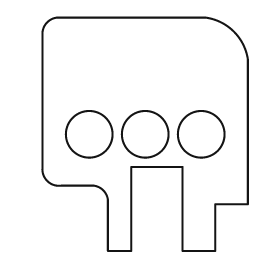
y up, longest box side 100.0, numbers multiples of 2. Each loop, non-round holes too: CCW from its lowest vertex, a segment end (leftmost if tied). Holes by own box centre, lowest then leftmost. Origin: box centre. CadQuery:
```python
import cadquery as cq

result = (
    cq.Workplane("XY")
    .moveTo(-16.0, -50.0)
    .lineTo(-6.0, -50.0)
    .lineTo(-6.0, -14.0)
    .lineTo(16.0, -14.0)
    .lineTo(16.0, -50.0)
    .lineTo(30.0, -50.0)
    .lineTo(30.0, -30.0)
    .lineTo(44.0, -30.0)
    .lineTo(44.0, 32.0)
    .threePointArc((38.0, 44.0), (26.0, 50.0))
    .lineTo(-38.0, 50.0)
    .threePointArc((-42.0, 48.0), (-44.0, 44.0))
    .lineTo(-44.0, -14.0)
    .threePointArc((-42.0, -20.0), (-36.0, -22.0))
    .lineTo(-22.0, -22.0)
    .threePointArc((-18.0, -24.0), (-16.0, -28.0))
    .close()
    .moveTo(-24.0, 0.0)
    .circle(10.0)
    .moveTo(0.0, 0.0)
    .circle(10.0)
    .moveTo(24.0, 0.0)
    .circle(10.0)
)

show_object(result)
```